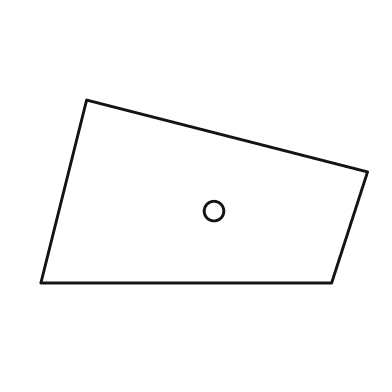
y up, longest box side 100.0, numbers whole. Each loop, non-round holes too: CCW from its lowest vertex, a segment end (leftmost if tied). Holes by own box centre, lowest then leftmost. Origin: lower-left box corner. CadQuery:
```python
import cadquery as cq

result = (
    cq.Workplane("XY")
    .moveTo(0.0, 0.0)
    .lineTo(89.0, 0.0)
    .lineTo(100.0, 34.0)
    .lineTo(14.0, 56.0)
    .close()
    .moveTo(53.0, 22.0)
    .circle(3.0)
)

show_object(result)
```